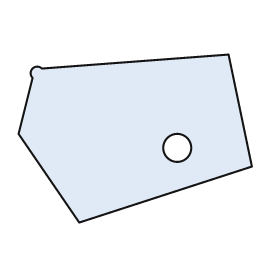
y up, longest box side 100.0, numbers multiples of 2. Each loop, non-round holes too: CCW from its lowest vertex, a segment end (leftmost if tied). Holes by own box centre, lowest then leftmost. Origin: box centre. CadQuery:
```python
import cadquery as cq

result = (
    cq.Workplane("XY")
    .moveTo(-24.0, -36.0)
    .lineTo(50.0, -12.0)
    .lineTo(40.0, 36.0)
    .lineTo(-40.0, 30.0)
    .threePointArc((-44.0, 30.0), (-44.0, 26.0))
    .lineTo(-50.0, 2.0)
    .close()
    .moveTo(18.0, -4.0)
    .circle(6.0)
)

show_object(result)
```